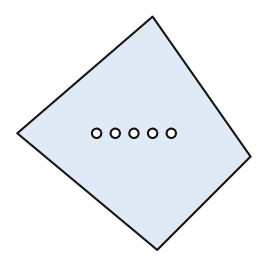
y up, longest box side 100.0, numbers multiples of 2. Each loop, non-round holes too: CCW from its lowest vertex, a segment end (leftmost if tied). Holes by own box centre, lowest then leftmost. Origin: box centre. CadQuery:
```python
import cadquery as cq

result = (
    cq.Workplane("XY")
    .moveTo(10.0, -50.0)
    .lineTo(50.0, -10.0)
    .lineTo(8.0, 50.0)
    .lineTo(-50.0, 0.0)
    .close()
    .moveTo(-16.0, 0.0)
    .circle(2.0)
    .moveTo(-8.0, 0.0)
    .circle(2.0)
    .moveTo(0.0, 0.0)
    .circle(2.0)
    .moveTo(8.0, 0.0)
    .circle(2.0)
    .moveTo(16.0, 0.0)
    .circle(2.0)
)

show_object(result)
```